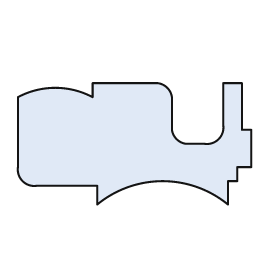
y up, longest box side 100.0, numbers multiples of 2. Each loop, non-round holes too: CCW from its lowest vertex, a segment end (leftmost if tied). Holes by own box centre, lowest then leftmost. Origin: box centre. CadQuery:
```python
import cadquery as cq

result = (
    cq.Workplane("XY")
    .moveTo(-16.0, -26.0)
    .threePointArc((12.0, -16.0), (40.0, -26.0))
    .lineTo(40.0, -16.0)
    .lineTo(44.0, -16.0)
    .lineTo(44.0, -10.0)
    .lineTo(50.0, -10.0)
    .lineTo(50.0, 6.0)
    .lineTo(46.0, 6.0)
    .lineTo(46.0, 26.0)
    .lineTo(38.0, 26.0)
    .lineTo(38.0, 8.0)
    .threePointArc((36.0, 2.0), (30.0, 0.0))
    .lineTo(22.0, 0.0)
    .threePointArc((18.0, 2.0), (16.0, 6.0))
    .lineTo(16.0, 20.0)
    .threePointArc((14.0, 24.0), (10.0, 26.0))
    .lineTo(-18.0, 26.0)
    .lineTo(-18.0, 20.0)
    .threePointArc((-34.0, 24.0), (-50.0, 20.0))
    .lineTo(-50.0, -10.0)
    .threePointArc((-48.0, -16.0), (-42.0, -18.0))
    .lineTo(-16.0, -18.0)
    .close()
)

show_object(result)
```